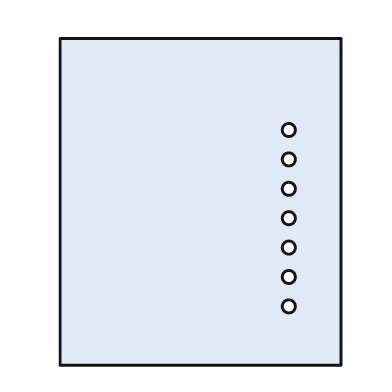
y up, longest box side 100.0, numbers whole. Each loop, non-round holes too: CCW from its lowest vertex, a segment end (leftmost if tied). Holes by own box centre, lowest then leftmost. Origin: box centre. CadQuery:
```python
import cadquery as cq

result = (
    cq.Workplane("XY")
    .moveTo(-43.0, -50.0)
    .lineTo(43.0, -50.0)
    .lineTo(43.0, 50.0)
    .lineTo(-43.0, 50.0)
    .close()
    .moveTo(27.0, -32.0)
    .circle(2.0)
    .moveTo(27.0, -23.0)
    .circle(2.0)
    .moveTo(27.0, -14.0)
    .circle(2.0)
    .moveTo(27.0, -5.0)
    .circle(2.0)
    .moveTo(27.0, 4.0)
    .circle(2.0)
    .moveTo(27.0, 13.0)
    .circle(2.0)
    .moveTo(27.0, 22.0)
    .circle(2.0)
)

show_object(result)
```